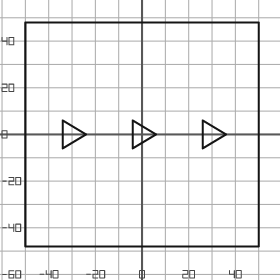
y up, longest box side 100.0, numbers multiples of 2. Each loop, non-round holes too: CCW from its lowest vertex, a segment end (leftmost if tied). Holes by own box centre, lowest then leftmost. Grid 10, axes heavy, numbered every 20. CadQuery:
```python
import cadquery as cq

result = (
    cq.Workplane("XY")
    .moveTo(-50.0, -48.0)
    .lineTo(50.0, -48.0)
    .lineTo(50.0, 48.0)
    .lineTo(-50.0, 48.0)
    .close()
    .moveTo(-34.0, -6.0)
    .lineTo(-24.0, 0.0)
    .lineTo(-34.0, 6.0)
    .close()
    .moveTo(-4.0, -6.0)
    .lineTo(6.0, 0.0)
    .lineTo(-4.0, 6.0)
    .close()
    .moveTo(26.0, -6.0)
    .lineTo(36.0, 0.0)
    .lineTo(26.0, 6.0)
    .close()
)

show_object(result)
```